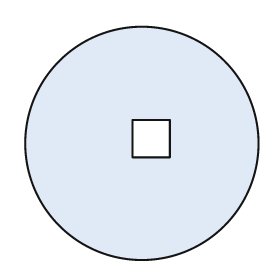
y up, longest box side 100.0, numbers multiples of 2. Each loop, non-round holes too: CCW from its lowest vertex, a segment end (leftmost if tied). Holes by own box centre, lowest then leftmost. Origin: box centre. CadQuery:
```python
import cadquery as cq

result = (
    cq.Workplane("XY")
    .moveTo(0.0, 0.0)
    .circle(50.0)
    .moveTo(-4.0, -6.0)
    .lineTo(12.0, -6.0)
    .lineTo(12.0, 10.0)
    .lineTo(-4.0, 10.0)
    .close()
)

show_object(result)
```